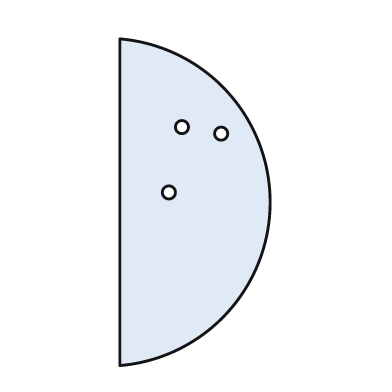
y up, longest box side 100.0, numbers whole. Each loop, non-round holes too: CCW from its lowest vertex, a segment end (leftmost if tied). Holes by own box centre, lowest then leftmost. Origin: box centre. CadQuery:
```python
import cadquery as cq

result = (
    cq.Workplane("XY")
    .moveTo(-23.0, -50.0)
    .threePointArc((23.0, 0.0), (-23.0, 50.0))
    .close()
    .moveTo(-8.0, 3.0)
    .circle(2.0)
    .moveTo(8.0, 21.0)
    .circle(2.0)
    .moveTo(-4.0, 23.0)
    .circle(2.0)
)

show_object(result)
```